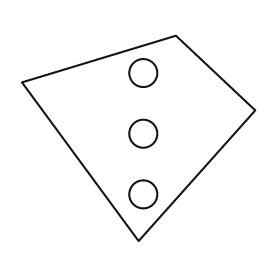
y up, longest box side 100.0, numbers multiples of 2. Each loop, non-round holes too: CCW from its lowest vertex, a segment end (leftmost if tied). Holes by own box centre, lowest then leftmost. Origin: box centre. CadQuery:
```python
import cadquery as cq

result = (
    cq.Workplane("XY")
    .moveTo(0.0, -44.0)
    .lineTo(50.0, 12.0)
    .lineTo(16.0, 44.0)
    .lineTo(-50.0, 24.0)
    .close()
    .moveTo(2.0, -24.0)
    .circle(6.0)
    .moveTo(2.0, 2.0)
    .circle(6.0)
    .moveTo(2.0, 28.0)
    .circle(6.0)
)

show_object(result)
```